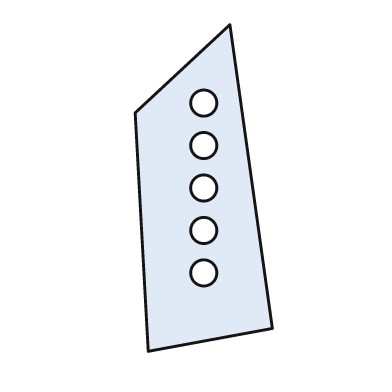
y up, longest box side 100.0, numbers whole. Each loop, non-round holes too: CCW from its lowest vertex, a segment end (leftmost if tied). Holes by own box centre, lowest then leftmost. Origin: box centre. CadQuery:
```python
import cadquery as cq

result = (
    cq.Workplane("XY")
    .moveTo(-17.0, -50.0)
    .lineTo(21.0, -43.0)
    .lineTo(8.0, 50.0)
    .lineTo(-21.0, 23.0)
    .close()
    .moveTo(0.0, -26.0)
    .circle(4.0)
    .moveTo(0.0, -13.0)
    .circle(4.0)
    .moveTo(0.0, 0.0)
    .circle(4.0)
    .moveTo(0.0, 13.0)
    .circle(4.0)
    .moveTo(0.0, 26.0)
    .circle(4.0)
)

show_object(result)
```